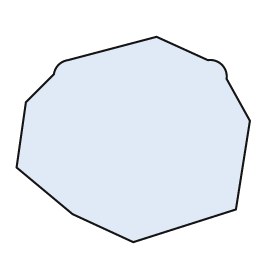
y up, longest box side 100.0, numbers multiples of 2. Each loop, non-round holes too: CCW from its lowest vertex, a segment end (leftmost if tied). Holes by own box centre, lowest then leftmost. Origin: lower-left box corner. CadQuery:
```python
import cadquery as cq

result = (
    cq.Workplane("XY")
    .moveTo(50.0, 0.0)
    .lineTo(94.0, 14.0)
    .lineTo(100.0, 52.0)
    .lineTo(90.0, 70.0)
    .threePointArc((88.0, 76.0), (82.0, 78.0))
    .lineTo(60.0, 88.0)
    .lineTo(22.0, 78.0)
    .threePointArc((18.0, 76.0), (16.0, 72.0))
    .lineTo(4.0, 60.0)
    .lineTo(0.0, 32.0)
    .lineTo(24.0, 12.0)
    .close()
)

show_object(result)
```